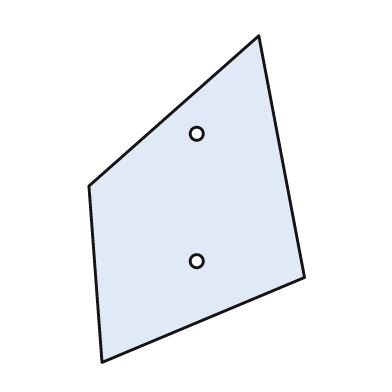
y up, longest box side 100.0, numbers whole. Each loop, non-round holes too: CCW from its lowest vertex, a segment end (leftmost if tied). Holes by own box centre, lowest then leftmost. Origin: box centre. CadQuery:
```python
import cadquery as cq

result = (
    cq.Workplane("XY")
    .moveTo(-29.0, -50.0)
    .lineTo(33.0, -24.0)
    .lineTo(19.0, 50.0)
    .lineTo(-33.0, 4.0)
    .close()
    .moveTo(0.0, -19.0)
    .circle(2.0)
    .moveTo(0.0, 20.0)
    .circle(2.0)
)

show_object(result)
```